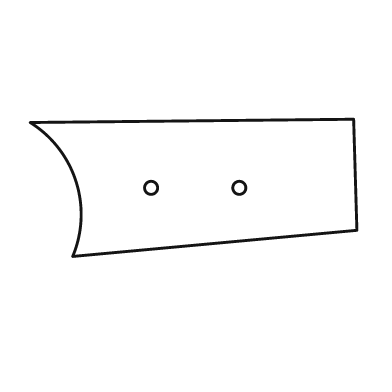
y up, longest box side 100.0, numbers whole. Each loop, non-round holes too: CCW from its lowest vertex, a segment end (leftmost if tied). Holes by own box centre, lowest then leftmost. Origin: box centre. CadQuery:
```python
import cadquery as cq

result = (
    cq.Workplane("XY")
    .moveTo(-37.0, -21.0)
    .lineTo(50.0, -13.0)
    .lineTo(49.0, 21.0)
    .lineTo(-50.0, 20.0)
    .threePointArc((-36.0, 2.0), (-37.0, -21.0))
    .close()
    .moveTo(-13.0, 0.0)
    .circle(2.0)
    .moveTo(14.0, 0.0)
    .circle(2.0)
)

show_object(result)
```